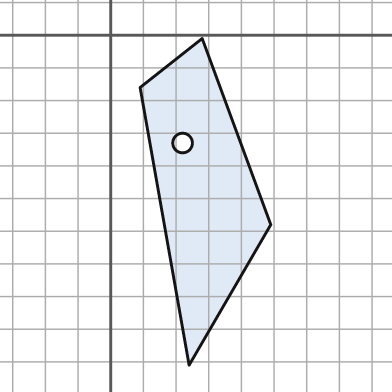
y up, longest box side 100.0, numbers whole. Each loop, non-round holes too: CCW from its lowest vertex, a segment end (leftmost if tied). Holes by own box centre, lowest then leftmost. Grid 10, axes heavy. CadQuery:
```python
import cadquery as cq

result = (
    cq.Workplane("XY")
    .moveTo(24.0, -101.0)
    .lineTo(49.0, -58.0)
    .lineTo(28.0, -1.0)
    .lineTo(9.0, -16.0)
    .close()
    .moveTo(22.0, -33.0)
    .circle(3.0)
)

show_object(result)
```